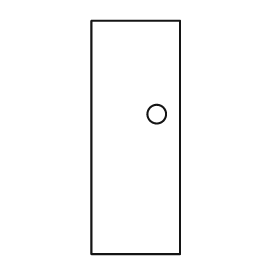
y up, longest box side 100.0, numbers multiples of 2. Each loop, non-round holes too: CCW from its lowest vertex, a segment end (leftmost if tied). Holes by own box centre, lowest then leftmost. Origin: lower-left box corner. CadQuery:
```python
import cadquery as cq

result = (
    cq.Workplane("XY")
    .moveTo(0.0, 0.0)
    .lineTo(38.0, 0.0)
    .lineTo(38.0, 100.0)
    .lineTo(0.0, 100.0)
    .close()
    .moveTo(28.0, 60.0)
    .circle(4.0)
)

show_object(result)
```